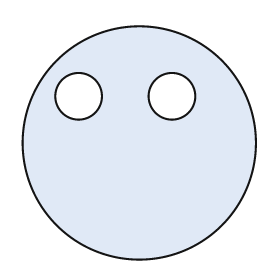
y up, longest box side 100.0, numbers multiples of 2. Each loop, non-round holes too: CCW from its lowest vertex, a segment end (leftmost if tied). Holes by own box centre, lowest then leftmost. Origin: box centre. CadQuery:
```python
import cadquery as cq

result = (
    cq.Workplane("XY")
    .moveTo(0.0, 0.0)
    .circle(50.0)
    .moveTo(-26.0, 20.0)
    .circle(10.0)
    .moveTo(14.0, 20.0)
    .circle(10.0)
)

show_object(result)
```